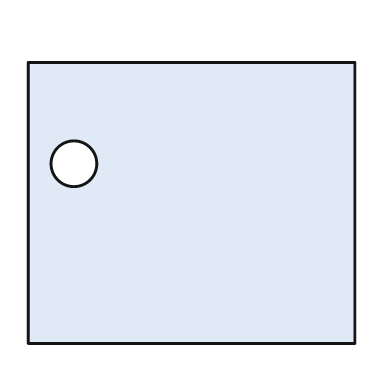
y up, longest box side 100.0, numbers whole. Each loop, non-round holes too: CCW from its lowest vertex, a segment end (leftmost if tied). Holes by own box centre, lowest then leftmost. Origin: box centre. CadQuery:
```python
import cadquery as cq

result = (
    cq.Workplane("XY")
    .moveTo(-50.0, -43.0)
    .lineTo(50.0, -43.0)
    .lineTo(50.0, 43.0)
    .lineTo(-50.0, 43.0)
    .close()
    .moveTo(-36.0, 12.0)
    .circle(7.0)
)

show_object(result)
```